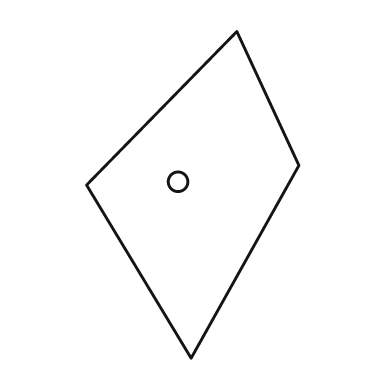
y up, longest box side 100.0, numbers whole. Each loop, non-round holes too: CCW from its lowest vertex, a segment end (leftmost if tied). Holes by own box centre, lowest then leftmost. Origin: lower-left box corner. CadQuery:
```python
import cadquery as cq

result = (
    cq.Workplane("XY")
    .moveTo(32.0, 0.0)
    .lineTo(65.0, 59.0)
    .lineTo(46.0, 100.0)
    .lineTo(0.0, 53.0)
    .close()
    .moveTo(28.0, 54.0)
    .circle(3.0)
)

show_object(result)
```